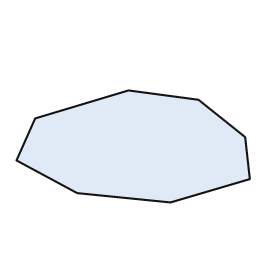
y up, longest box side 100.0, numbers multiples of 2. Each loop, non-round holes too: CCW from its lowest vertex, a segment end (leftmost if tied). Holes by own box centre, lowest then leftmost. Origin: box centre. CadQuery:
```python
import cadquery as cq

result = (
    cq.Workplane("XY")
    .moveTo(16.0, -24.0)
    .lineTo(50.0, -14.0)
    .lineTo(48.0, 4.0)
    .lineTo(28.0, 20.0)
    .lineTo(-2.0, 24.0)
    .lineTo(-42.0, 12.0)
    .lineTo(-50.0, -6.0)
    .lineTo(-24.0, -20.0)
    .close()
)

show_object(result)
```